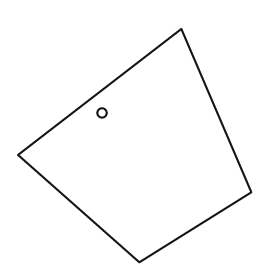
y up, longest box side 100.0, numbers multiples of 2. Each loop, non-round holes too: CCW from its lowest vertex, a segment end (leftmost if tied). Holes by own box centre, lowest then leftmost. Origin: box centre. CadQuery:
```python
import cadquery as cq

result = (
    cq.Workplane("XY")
    .moveTo(2.0, -50.0)
    .lineTo(50.0, -20.0)
    .lineTo(20.0, 50.0)
    .lineTo(-50.0, -4.0)
    .close()
    .moveTo(-14.0, 14.0)
    .circle(2.0)
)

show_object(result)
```